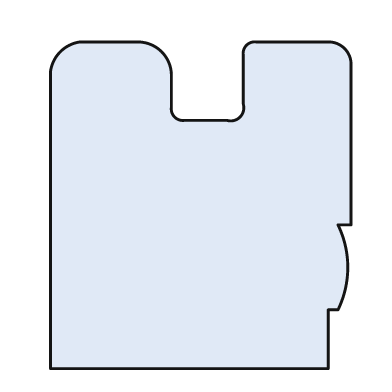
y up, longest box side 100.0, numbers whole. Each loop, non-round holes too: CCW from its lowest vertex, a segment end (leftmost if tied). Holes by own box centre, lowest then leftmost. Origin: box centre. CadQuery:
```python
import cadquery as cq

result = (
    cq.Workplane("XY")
    .moveTo(-46.0, -50.0)
    .lineTo(39.0, -50.0)
    .lineTo(39.0, -32.0)
    .lineTo(42.0, -32.0)
    .threePointArc((45.0, -19.0), (42.0, -6.0))
    .lineTo(46.0, -6.0)
    .lineTo(46.0, 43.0)
    .threePointArc((44.0, 48.0), (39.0, 50.0))
    .lineTo(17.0, 50.0)
    .threePointArc((14.0, 49.0), (13.0, 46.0))
    .lineTo(13.0, 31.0)
    .threePointArc((12.0, 27.0), (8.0, 26.0))
    .lineTo(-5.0, 26.0)
    .threePointArc((-8.0, 27.0), (-9.0, 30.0))
    .lineTo(-9.0, 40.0)
    .threePointArc((-12.0, 47.0), (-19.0, 50.0))
    .lineTo(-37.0, 50.0)
    .threePointArc((-43.0, 47.0), (-46.0, 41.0))
    .close()
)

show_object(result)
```